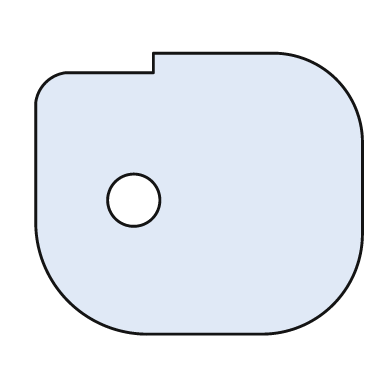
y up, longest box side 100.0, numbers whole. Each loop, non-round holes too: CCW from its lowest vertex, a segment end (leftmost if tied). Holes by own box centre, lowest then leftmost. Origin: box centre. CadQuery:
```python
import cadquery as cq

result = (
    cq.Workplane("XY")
    .moveTo(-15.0, -43.0)
    .lineTo(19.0, -43.0)
    .threePointArc((41.0, -34.0), (50.0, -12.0))
    .lineTo(50.0, 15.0)
    .threePointArc((42.0, 35.0), (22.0, 43.0))
    .lineTo(-14.0, 43.0)
    .lineTo(-14.0, 37.0)
    .lineTo(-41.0, 37.0)
    .threePointArc((-47.0, 34.0), (-50.0, 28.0))
    .lineTo(-50.0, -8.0)
    .threePointArc((-40.0, -33.0), (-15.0, -43.0))
    .close()
    .moveTo(-20.0, -2.0)
    .circle(8.0)
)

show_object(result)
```